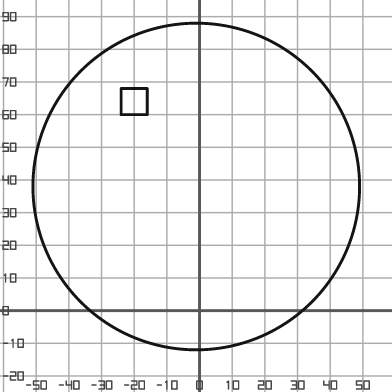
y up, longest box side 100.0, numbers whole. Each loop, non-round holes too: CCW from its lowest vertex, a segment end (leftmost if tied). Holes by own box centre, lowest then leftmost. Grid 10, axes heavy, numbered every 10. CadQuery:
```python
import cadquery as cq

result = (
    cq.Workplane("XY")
    .moveTo(-1.0, 38.0)
    .circle(50.0)
    .moveTo(-24.0, 60.0)
    .lineTo(-16.0, 60.0)
    .lineTo(-16.0, 68.0)
    .lineTo(-24.0, 68.0)
    .close()
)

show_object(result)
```